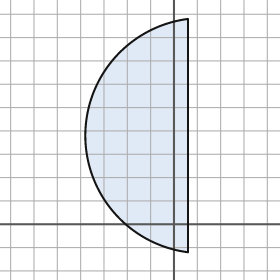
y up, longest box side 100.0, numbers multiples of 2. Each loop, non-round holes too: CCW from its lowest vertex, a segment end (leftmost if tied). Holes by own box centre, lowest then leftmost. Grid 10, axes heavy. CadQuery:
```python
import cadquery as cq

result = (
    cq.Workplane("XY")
    .moveTo(6.0, -12.0)
    .lineTo(6.0, 88.0)
    .threePointArc((-38.0, 38.0), (6.0, -12.0))
    .close()
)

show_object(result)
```